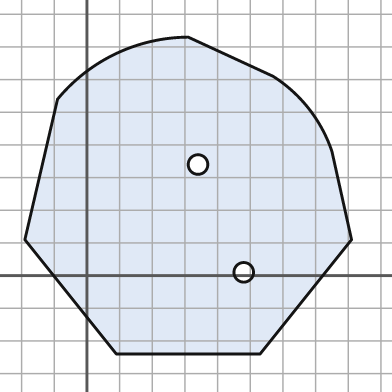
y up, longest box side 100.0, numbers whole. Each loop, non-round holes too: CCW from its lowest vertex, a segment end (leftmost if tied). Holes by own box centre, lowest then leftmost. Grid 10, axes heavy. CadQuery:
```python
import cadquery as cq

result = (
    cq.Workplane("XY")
    .moveTo(9.0, -24.0)
    .lineTo(53.0, -24.0)
    .lineTo(81.0, 11.0)
    .lineTo(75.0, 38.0)
    .threePointArc((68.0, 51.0), (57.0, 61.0))
    .lineTo(31.0, 73.0)
    .threePointArc((9.0, 68.0), (-9.0, 54.0))
    .lineTo(-19.0, 11.0)
    .close()
    .moveTo(48.0, 1.0)
    .circle(3.0)
    .moveTo(34.0, 34.0)
    .circle(3.0)
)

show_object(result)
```